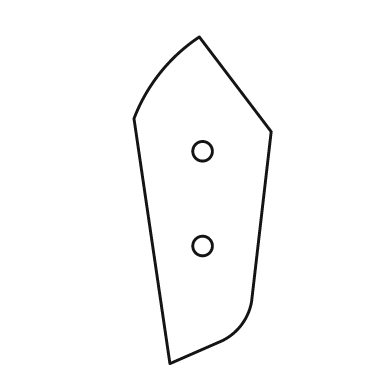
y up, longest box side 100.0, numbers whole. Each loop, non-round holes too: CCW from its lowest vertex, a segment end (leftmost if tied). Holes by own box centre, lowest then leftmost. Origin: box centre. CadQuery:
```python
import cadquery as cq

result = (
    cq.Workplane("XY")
    .moveTo(-10.0, -50.0)
    .lineTo(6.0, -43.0)
    .threePointArc((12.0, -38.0), (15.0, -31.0))
    .lineTo(21.0, 21.0)
    .lineTo(-1.0, 50.0)
    .threePointArc((-13.0, 39.0), (-21.0, 25.0))
    .close()
    .moveTo(0.0, -14.0)
    .circle(3.0)
    .moveTo(0.0, 15.0)
    .circle(3.0)
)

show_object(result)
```